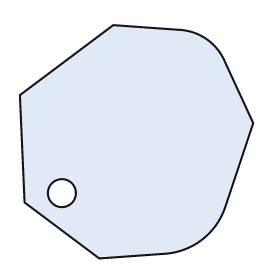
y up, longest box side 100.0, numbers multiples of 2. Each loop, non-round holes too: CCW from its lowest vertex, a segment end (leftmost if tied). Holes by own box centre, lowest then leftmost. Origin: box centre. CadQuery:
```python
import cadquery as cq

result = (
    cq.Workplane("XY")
    .moveTo(-16.0, -50.0)
    .lineTo(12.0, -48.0)
    .threePointArc((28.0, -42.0), (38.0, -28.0))
    .lineTo(50.0, 8.0)
    .lineTo(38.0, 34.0)
    .threePointArc((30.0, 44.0), (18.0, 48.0))
    .lineTo(-10.0, 50.0)
    .lineTo(-50.0, 20.0)
    .lineTo(-48.0, -26.0)
    .close()
    .moveTo(-32.0, -22.0)
    .circle(6.0)
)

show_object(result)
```